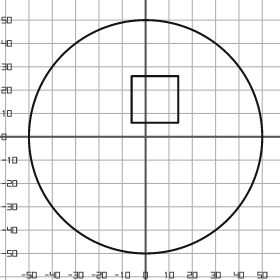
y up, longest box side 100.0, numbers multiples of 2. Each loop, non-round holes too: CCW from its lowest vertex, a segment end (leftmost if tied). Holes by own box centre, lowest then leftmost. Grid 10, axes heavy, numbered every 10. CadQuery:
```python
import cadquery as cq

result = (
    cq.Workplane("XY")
    .moveTo(0.0, 0.0)
    .circle(50.0)
    .moveTo(-6.0, 6.0)
    .lineTo(14.0, 6.0)
    .lineTo(14.0, 26.0)
    .lineTo(-6.0, 26.0)
    .close()
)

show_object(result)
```